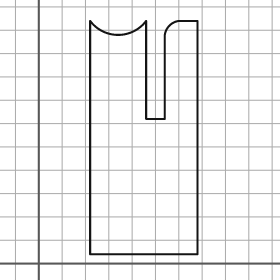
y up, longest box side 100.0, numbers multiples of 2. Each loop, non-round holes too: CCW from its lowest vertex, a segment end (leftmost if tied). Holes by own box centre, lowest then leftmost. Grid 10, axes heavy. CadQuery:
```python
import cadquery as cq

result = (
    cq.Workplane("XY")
    .moveTo(22.0, 4.0)
    .lineTo(68.0, 4.0)
    .lineTo(68.0, 104.0)
    .lineTo(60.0, 104.0)
    .threePointArc((56.0, 102.0), (54.0, 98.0))
    .lineTo(54.0, 62.0)
    .lineTo(46.0, 62.0)
    .lineTo(46.0, 104.0)
    .threePointArc((34.0, 98.0), (22.0, 104.0))
    .close()
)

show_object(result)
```